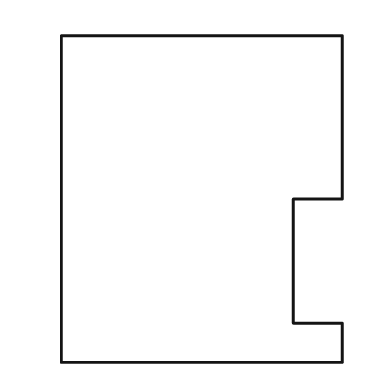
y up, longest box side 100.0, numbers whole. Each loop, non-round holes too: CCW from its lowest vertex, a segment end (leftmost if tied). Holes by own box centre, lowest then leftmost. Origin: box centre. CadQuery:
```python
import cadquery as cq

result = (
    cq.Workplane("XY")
    .moveTo(-43.0, -50.0)
    .lineTo(43.0, -50.0)
    .lineTo(43.0, -38.0)
    .lineTo(28.0, -38.0)
    .lineTo(28.0, 0.0)
    .lineTo(43.0, 0.0)
    .lineTo(43.0, 50.0)
    .lineTo(-43.0, 50.0)
    .close()
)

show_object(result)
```